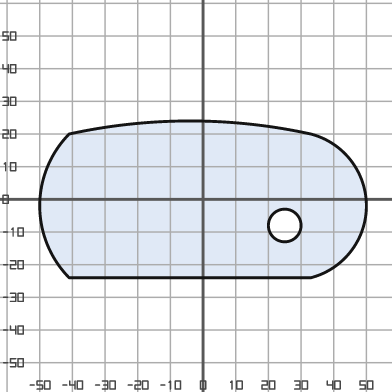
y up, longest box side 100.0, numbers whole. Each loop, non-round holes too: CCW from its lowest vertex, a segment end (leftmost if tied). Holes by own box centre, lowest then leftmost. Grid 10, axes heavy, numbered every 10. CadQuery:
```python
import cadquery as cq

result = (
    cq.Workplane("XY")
    .moveTo(-41.0, -24.0)
    .lineTo(33.0, -24.0)
    .threePointArc((50.0, -2.0), (33.0, 20.0))
    .threePointArc((-4.0, 24.0), (-41.0, 20.0))
    .threePointArc((-50.0, -2.0), (-41.0, -24.0))
    .close()
    .moveTo(25.0, -8.0)
    .circle(5.0)
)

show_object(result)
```